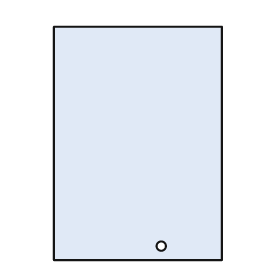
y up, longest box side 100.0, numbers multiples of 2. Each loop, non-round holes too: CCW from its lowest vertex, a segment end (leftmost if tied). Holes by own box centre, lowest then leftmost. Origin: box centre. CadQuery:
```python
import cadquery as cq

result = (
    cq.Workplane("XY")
    .moveTo(-36.0, -50.0)
    .lineTo(36.0, -50.0)
    .lineTo(36.0, 50.0)
    .lineTo(-36.0, 50.0)
    .close()
    .moveTo(10.0, -44.0)
    .circle(2.0)
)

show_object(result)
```